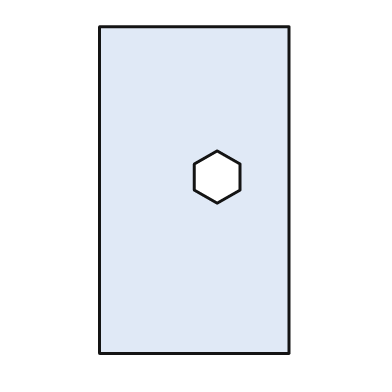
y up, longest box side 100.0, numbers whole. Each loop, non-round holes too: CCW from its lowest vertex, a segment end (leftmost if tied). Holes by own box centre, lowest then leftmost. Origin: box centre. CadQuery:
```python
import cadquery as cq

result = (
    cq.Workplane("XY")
    .moveTo(-29.0, -50.0)
    .lineTo(29.0, -50.0)
    .lineTo(29.0, 50.0)
    .lineTo(-29.0, 50.0)
    .close()
    .moveTo(7.0, -4.0)
    .lineTo(14.0, 0.0)
    .lineTo(14.0, 8.0)
    .lineTo(7.0, 12.0)
    .lineTo(0.0, 8.0)
    .lineTo(0.0, 0.0)
    .close()
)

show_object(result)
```